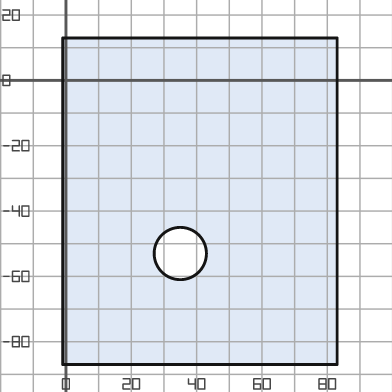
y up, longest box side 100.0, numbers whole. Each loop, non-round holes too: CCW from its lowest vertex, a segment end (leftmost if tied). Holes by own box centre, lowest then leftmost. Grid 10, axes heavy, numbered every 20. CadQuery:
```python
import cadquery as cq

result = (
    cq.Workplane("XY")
    .moveTo(-1.0, -87.0)
    .lineTo(83.0, -87.0)
    .lineTo(83.0, 13.0)
    .lineTo(-1.0, 13.0)
    .close()
    .moveTo(35.0, -53.0)
    .circle(8.0)
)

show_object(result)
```